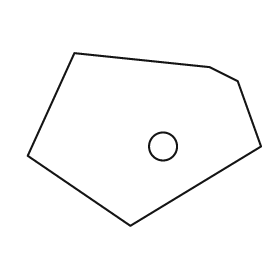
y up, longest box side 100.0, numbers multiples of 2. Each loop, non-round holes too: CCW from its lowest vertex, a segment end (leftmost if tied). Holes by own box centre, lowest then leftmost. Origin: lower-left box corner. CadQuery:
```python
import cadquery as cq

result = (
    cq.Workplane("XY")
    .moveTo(44.0, 0.0)
    .lineTo(100.0, 34.0)
    .lineTo(90.0, 62.0)
    .lineTo(78.0, 68.0)
    .lineTo(20.0, 74.0)
    .lineTo(0.0, 30.0)
    .close()
    .moveTo(58.0, 34.0)
    .circle(6.0)
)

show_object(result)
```